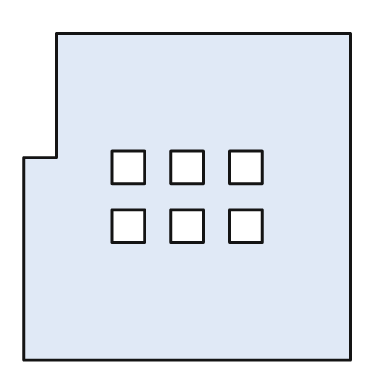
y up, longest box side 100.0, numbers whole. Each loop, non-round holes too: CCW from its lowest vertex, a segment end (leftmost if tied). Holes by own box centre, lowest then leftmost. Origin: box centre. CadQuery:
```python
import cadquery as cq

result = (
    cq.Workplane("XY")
    .moveTo(-50.0, -50.0)
    .lineTo(50.0, -50.0)
    .lineTo(50.0, 50.0)
    .lineTo(-40.0, 50.0)
    .lineTo(-40.0, 12.0)
    .lineTo(-50.0, 12.0)
    .close()
    .moveTo(-23.0, -14.0)
    .lineTo(-13.0, -14.0)
    .lineTo(-13.0, -4.0)
    .lineTo(-23.0, -4.0)
    .close()
    .moveTo(-5.0, -14.0)
    .lineTo(5.0, -14.0)
    .lineTo(5.0, -4.0)
    .lineTo(-5.0, -4.0)
    .close()
    .moveTo(13.0, -14.0)
    .lineTo(23.0, -14.0)
    .lineTo(23.0, -4.0)
    .lineTo(13.0, -4.0)
    .close()
    .moveTo(-23.0, 4.0)
    .lineTo(-13.0, 4.0)
    .lineTo(-13.0, 14.0)
    .lineTo(-23.0, 14.0)
    .close()
    .moveTo(-5.0, 4.0)
    .lineTo(5.0, 4.0)
    .lineTo(5.0, 14.0)
    .lineTo(-5.0, 14.0)
    .close()
    .moveTo(13.0, 4.0)
    .lineTo(23.0, 4.0)
    .lineTo(23.0, 14.0)
    .lineTo(13.0, 14.0)
    .close()
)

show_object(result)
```